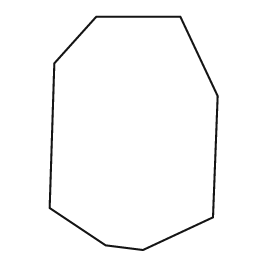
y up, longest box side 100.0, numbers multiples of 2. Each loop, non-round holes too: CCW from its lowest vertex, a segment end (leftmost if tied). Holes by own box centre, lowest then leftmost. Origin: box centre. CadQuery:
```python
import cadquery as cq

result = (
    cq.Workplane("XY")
    .moveTo(4.0, -50.0)
    .lineTo(34.0, -36.0)
    .lineTo(36.0, 16.0)
    .lineTo(20.0, 50.0)
    .lineTo(-16.0, 50.0)
    .lineTo(-34.0, 30.0)
    .lineTo(-36.0, -32.0)
    .lineTo(-12.0, -48.0)
    .close()
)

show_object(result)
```